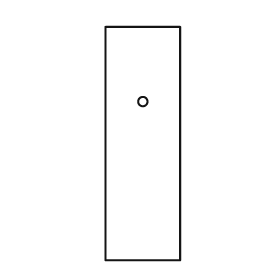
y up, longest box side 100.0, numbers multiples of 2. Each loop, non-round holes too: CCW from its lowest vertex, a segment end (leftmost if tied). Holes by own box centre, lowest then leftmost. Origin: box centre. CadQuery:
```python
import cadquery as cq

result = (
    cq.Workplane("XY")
    .moveTo(-16.0, -50.0)
    .lineTo(16.0, -50.0)
    .lineTo(16.0, 50.0)
    .lineTo(-16.0, 50.0)
    .close()
    .moveTo(0.0, 18.0)
    .circle(2.0)
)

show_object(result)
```